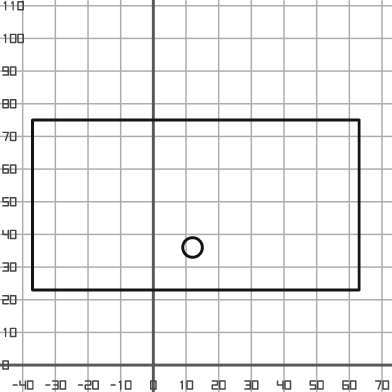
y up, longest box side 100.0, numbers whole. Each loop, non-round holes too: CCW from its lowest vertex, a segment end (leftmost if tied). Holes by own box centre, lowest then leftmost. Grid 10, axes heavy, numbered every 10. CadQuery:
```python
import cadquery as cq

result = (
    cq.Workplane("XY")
    .moveTo(-37.0, 23.0)
    .lineTo(63.0, 23.0)
    .lineTo(63.0, 75.0)
    .lineTo(-37.0, 75.0)
    .close()
    .moveTo(12.0, 36.0)
    .circle(3.0)
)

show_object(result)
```